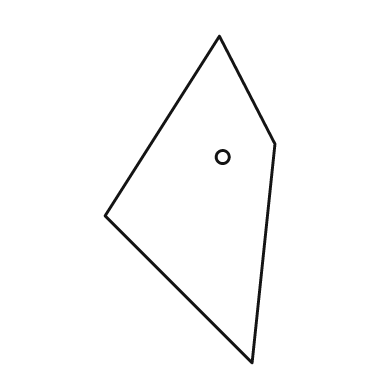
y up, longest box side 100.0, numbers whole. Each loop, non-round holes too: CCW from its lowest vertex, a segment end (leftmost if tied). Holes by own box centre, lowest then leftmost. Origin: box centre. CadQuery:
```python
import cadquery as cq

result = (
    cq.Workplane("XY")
    .moveTo(19.0, -50.0)
    .lineTo(26.0, 17.0)
    .lineTo(9.0, 50.0)
    .lineTo(-26.0, -5.0)
    .close()
    .moveTo(10.0, 13.0)
    .circle(2.0)
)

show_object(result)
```